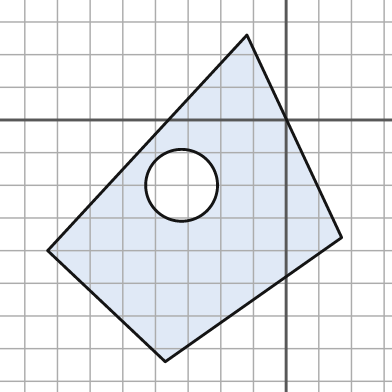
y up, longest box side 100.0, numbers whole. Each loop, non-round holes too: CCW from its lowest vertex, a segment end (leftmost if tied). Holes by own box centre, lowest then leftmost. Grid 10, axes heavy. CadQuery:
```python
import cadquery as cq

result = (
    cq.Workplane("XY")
    .moveTo(-37.0, -74.0)
    .lineTo(17.0, -36.0)
    .lineTo(-12.0, 26.0)
    .lineTo(-73.0, -40.0)
    .close()
    .moveTo(-32.0, -20.0)
    .circle(11.0)
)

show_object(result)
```